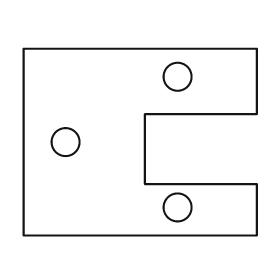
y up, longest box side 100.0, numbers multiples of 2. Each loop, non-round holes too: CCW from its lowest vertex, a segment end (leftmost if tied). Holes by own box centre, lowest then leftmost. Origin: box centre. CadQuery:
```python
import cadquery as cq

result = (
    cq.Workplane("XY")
    .moveTo(-50.0, -40.0)
    .lineTo(50.0, -40.0)
    .lineTo(50.0, -18.0)
    .lineTo(2.0, -18.0)
    .lineTo(2.0, 12.0)
    .lineTo(50.0, 12.0)
    .lineTo(50.0, 40.0)
    .lineTo(-50.0, 40.0)
    .close()
    .moveTo(16.0, -28.0)
    .circle(6.0)
    .moveTo(-32.0, 0.0)
    .circle(6.0)
    .moveTo(16.0, 28.0)
    .circle(6.0)
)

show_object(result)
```